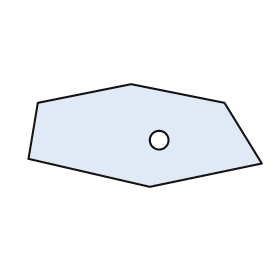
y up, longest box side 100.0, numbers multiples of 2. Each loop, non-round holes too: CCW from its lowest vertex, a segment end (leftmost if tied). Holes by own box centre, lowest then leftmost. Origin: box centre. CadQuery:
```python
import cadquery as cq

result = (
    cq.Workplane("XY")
    .moveTo(2.0, -22.0)
    .lineTo(50.0, -12.0)
    .lineTo(34.0, 14.0)
    .lineTo(-6.0, 22.0)
    .lineTo(-46.0, 14.0)
    .lineTo(-50.0, -10.0)
    .close()
    .moveTo(6.0, -2.0)
    .circle(4.0)
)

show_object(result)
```